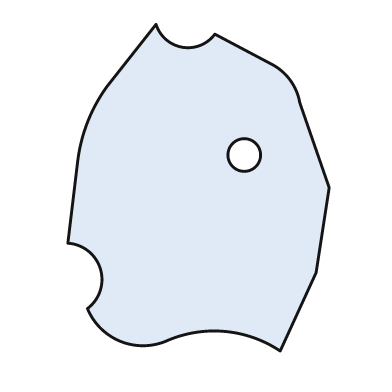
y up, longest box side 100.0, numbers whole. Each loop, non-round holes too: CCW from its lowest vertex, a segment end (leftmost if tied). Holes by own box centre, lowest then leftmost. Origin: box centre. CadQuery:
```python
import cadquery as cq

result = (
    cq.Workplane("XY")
    .moveTo(25.0, -50.0)
    .lineTo(36.0, -26.0)
    .lineTo(40.0, 0.0)
    .lineTo(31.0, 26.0)
    .threePointArc((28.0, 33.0), (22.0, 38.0))
    .lineTo(5.0, 47.0)
    .threePointArc((-5.0, 43.0), (-13.0, 50.0))
    .lineTo(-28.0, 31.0)
    .threePointArc((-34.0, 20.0), (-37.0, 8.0))
    .lineTo(-40.0, -17.0)
    .threePointArc((-30.0, -25.0), (-34.0, -37.0))
    .threePointArc((-24.0, -47.0), (-10.0, -47.0))
    .threePointArc((8.0, -44.0), (25.0, -50.0))
    .close()
    .moveTo(14.0, 10.0)
    .circle(5.0)
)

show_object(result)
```